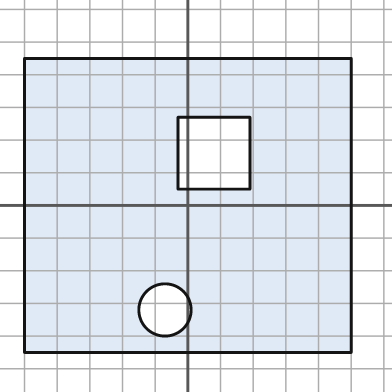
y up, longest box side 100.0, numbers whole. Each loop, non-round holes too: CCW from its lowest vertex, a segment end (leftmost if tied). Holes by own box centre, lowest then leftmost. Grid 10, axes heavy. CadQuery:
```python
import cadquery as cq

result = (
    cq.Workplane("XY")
    .moveTo(-50.0, -45.0)
    .lineTo(50.0, -45.0)
    .lineTo(50.0, 45.0)
    .lineTo(-50.0, 45.0)
    .close()
    .moveTo(-7.0, -32.0)
    .circle(8.0)
    .moveTo(-3.0, 5.0)
    .lineTo(19.0, 5.0)
    .lineTo(19.0, 27.0)
    .lineTo(-3.0, 27.0)
    .close()
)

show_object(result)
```